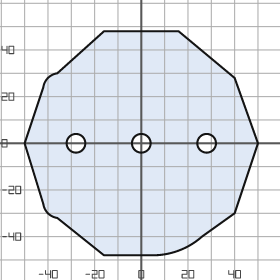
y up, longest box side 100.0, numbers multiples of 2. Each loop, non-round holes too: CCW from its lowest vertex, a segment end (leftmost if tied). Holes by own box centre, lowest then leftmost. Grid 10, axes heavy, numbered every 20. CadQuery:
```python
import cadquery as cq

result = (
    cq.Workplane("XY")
    .moveTo(-16.0, -48.0)
    .lineTo(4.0, -48.0)
    .threePointArc((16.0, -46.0), (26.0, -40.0))
    .lineTo(40.0, -30.0)
    .lineTo(50.0, 0.0)
    .lineTo(40.0, 28.0)
    .lineTo(16.0, 48.0)
    .lineTo(-16.0, 48.0)
    .lineTo(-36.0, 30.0)
    .threePointArc((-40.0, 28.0), (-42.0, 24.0))
    .lineTo(-50.0, 0.0)
    .lineTo(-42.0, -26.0)
    .threePointArc((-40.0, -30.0), (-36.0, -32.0))
    .close()
    .moveTo(-28.0, 0.0)
    .circle(4.0)
    .moveTo(0.0, 0.0)
    .circle(4.0)
    .moveTo(28.0, 0.0)
    .circle(4.0)
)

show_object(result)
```